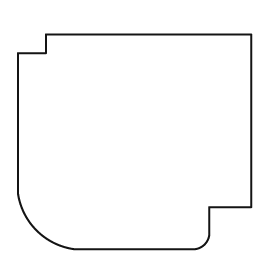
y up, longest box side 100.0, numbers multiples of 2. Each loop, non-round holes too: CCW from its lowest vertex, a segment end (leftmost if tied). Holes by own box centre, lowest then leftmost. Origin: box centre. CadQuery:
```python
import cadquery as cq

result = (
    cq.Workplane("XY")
    .moveTo(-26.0, -46.0)
    .lineTo(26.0, -46.0)
    .threePointArc((30.0, -44.0), (32.0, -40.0))
    .lineTo(32.0, -28.0)
    .lineTo(50.0, -28.0)
    .lineTo(50.0, 46.0)
    .lineTo(-38.0, 46.0)
    .lineTo(-38.0, 38.0)
    .lineTo(-50.0, 38.0)
    .lineTo(-50.0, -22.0)
    .threePointArc((-42.0, -38.0), (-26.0, -46.0))
    .close()
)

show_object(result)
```